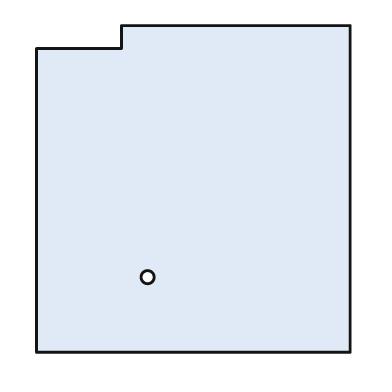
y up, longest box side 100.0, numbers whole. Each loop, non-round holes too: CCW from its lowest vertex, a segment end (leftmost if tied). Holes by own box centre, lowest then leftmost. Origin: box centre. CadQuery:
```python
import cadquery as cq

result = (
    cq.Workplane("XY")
    .moveTo(-48.0, -50.0)
    .lineTo(48.0, -50.0)
    .lineTo(48.0, 50.0)
    .lineTo(-22.0, 50.0)
    .lineTo(-22.0, 43.0)
    .lineTo(-48.0, 43.0)
    .close()
    .moveTo(-14.0, -27.0)
    .circle(2.0)
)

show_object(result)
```